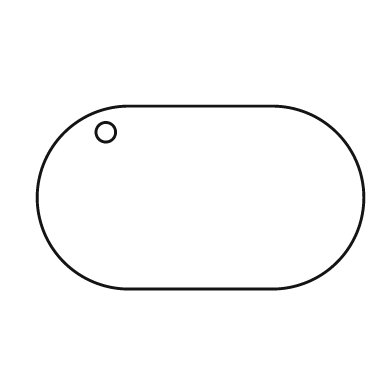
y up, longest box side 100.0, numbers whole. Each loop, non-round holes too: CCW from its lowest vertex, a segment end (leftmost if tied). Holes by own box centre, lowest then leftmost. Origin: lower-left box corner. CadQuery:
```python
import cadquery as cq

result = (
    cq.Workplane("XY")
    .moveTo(28.0, 0.0)
    .lineTo(72.0, 0.0)
    .threePointArc((100.0, 28.0), (72.0, 56.0))
    .lineTo(28.0, 56.0)
    .threePointArc((0.0, 28.0), (28.0, 0.0))
    .close()
    .moveTo(21.0, 48.0)
    .circle(3.0)
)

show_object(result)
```